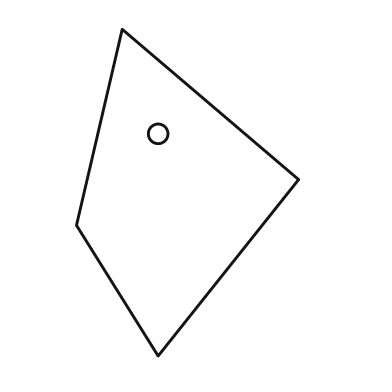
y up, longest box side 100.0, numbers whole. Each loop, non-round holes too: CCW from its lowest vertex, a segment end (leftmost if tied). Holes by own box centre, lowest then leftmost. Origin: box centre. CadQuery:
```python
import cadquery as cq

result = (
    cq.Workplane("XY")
    .moveTo(-9.0, -50.0)
    .lineTo(34.0, 4.0)
    .lineTo(-20.0, 50.0)
    .lineTo(-34.0, -10.0)
    .close()
    .moveTo(-9.0, 18.0)
    .circle(3.0)
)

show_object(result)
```